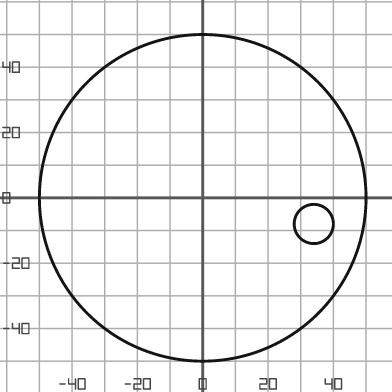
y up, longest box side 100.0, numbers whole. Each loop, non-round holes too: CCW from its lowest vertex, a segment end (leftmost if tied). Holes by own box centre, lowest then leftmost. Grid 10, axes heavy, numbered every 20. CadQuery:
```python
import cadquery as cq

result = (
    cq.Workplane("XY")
    .moveTo(0.0, 0.0)
    .circle(50.0)
    .moveTo(34.0, -8.0)
    .circle(6.0)
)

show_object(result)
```